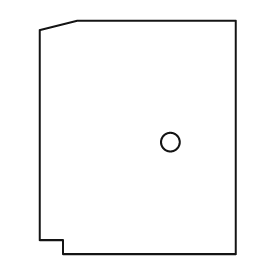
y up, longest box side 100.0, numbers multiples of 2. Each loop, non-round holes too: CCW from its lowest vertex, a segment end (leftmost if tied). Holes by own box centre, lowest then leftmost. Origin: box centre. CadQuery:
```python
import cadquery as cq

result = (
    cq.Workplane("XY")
    .moveTo(-32.0, -50.0)
    .lineTo(42.0, -50.0)
    .lineTo(42.0, 50.0)
    .lineTo(-26.0, 50.0)
    .lineTo(-42.0, 46.0)
    .lineTo(-42.0, -44.0)
    .lineTo(-32.0, -44.0)
    .close()
    .moveTo(14.0, -2.0)
    .circle(4.0)
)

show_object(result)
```